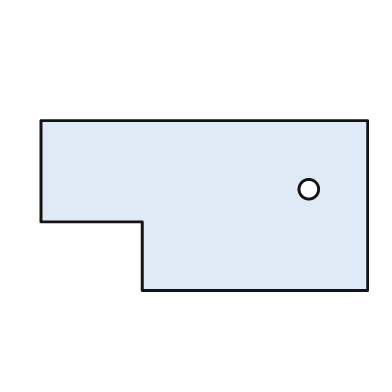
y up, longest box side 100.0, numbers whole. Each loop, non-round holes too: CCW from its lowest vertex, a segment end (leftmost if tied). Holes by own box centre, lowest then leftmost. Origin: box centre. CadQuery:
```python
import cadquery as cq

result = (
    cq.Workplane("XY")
    .moveTo(-19.0, -26.0)
    .lineTo(50.0, -26.0)
    .lineTo(50.0, 26.0)
    .lineTo(-50.0, 26.0)
    .lineTo(-50.0, -5.0)
    .lineTo(-19.0, -5.0)
    .close()
    .moveTo(32.0, 5.0)
    .circle(3.0)
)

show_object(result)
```